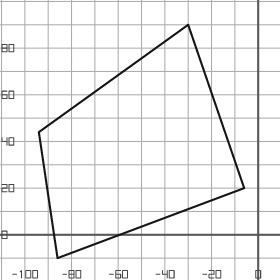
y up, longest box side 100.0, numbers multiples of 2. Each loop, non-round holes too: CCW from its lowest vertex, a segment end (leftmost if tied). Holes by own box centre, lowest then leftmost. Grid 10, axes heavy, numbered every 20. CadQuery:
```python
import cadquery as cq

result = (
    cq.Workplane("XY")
    .moveTo(-86.0, -10.0)
    .lineTo(-6.0, 20.0)
    .lineTo(-30.0, 90.0)
    .lineTo(-94.0, 44.0)
    .close()
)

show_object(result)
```